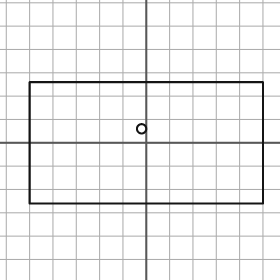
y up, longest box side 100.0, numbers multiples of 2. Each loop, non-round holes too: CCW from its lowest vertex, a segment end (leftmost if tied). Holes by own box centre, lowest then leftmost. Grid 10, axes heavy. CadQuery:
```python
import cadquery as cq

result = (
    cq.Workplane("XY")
    .moveTo(-50.0, -26.0)
    .lineTo(50.0, -26.0)
    .lineTo(50.0, 26.0)
    .lineTo(-50.0, 26.0)
    .close()
    .moveTo(-2.0, 6.0)
    .circle(2.0)
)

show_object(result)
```